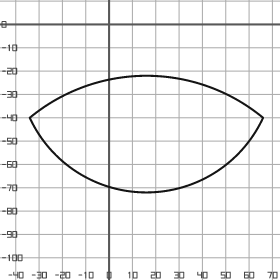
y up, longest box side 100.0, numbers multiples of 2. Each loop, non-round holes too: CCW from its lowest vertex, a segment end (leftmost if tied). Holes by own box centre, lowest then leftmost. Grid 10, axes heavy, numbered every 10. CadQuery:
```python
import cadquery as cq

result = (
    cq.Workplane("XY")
    .moveTo(-34.0, -40.0)
    .threePointArc((16.0, -72.0), (66.0, -40.0))
    .threePointArc((16.0, -22.0), (-34.0, -40.0))
    .close()
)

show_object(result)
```